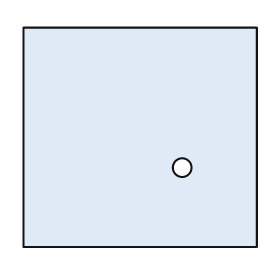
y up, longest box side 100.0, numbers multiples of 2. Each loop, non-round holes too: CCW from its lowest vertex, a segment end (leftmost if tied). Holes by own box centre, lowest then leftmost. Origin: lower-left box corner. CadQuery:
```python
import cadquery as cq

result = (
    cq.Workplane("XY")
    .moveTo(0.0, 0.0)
    .lineTo(100.0, 0.0)
    .lineTo(100.0, 94.0)
    .lineTo(0.0, 94.0)
    .close()
    .moveTo(68.0, 34.0)
    .circle(4.0)
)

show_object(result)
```